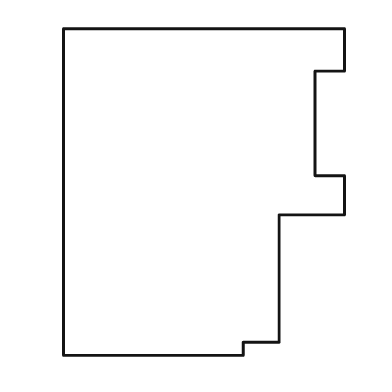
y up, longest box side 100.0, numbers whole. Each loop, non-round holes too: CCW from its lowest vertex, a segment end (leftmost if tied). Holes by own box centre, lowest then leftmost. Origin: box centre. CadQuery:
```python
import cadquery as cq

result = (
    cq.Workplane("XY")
    .moveTo(-43.0, -50.0)
    .lineTo(12.0, -50.0)
    .lineTo(12.0, -46.0)
    .lineTo(23.0, -46.0)
    .lineTo(23.0, -7.0)
    .lineTo(43.0, -7.0)
    .lineTo(43.0, 5.0)
    .lineTo(34.0, 5.0)
    .lineTo(34.0, 37.0)
    .lineTo(43.0, 37.0)
    .lineTo(43.0, 50.0)
    .lineTo(-43.0, 50.0)
    .close()
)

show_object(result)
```